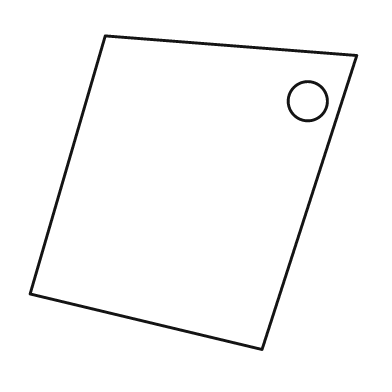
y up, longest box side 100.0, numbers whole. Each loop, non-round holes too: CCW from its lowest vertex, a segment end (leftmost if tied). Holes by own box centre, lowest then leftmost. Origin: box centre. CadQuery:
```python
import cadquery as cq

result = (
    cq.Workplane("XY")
    .moveTo(21.0, -48.0)
    .lineTo(50.0, 42.0)
    .lineTo(-27.0, 48.0)
    .lineTo(-50.0, -31.0)
    .close()
    .moveTo(35.0, 28.0)
    .circle(6.0)
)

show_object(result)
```